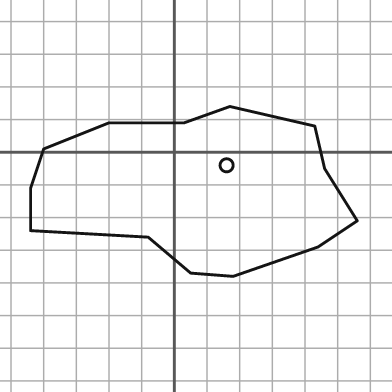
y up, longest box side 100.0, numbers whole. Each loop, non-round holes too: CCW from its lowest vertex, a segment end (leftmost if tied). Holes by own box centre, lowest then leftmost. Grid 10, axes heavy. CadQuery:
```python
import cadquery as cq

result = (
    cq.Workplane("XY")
    .moveTo(18.0, -38.0)
    .lineTo(44.0, -29.0)
    .lineTo(56.0, -21.0)
    .lineTo(46.0, -5.0)
    .lineTo(43.0, 8.0)
    .lineTo(17.0, 14.0)
    .lineTo(3.0, 9.0)
    .lineTo(-20.0, 9.0)
    .lineTo(-40.0, 1.0)
    .lineTo(-44.0, -11.0)
    .lineTo(-44.0, -24.0)
    .lineTo(-8.0, -26.0)
    .lineTo(5.0, -37.0)
    .close()
    .moveTo(16.0, -4.0)
    .circle(2.0)
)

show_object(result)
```